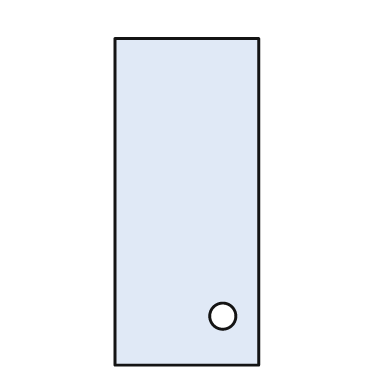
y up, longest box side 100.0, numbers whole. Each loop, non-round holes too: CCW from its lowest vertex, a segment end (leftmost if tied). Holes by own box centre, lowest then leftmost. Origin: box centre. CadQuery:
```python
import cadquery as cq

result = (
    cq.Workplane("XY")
    .moveTo(-22.0, -50.0)
    .lineTo(22.0, -50.0)
    .lineTo(22.0, 50.0)
    .lineTo(-22.0, 50.0)
    .close()
    .moveTo(11.0, -35.0)
    .circle(4.0)
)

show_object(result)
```